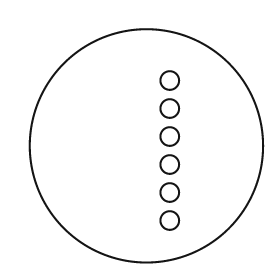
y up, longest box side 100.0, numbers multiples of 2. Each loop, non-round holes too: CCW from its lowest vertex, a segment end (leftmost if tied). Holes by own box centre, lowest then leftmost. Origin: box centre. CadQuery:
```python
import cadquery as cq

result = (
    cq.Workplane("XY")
    .moveTo(0.0, 0.0)
    .circle(50.0)
    .moveTo(10.0, -32.0)
    .circle(4.0)
    .moveTo(10.0, -20.0)
    .circle(4.0)
    .moveTo(10.0, -8.0)
    .circle(4.0)
    .moveTo(10.0, 4.0)
    .circle(4.0)
    .moveTo(10.0, 16.0)
    .circle(4.0)
    .moveTo(10.0, 28.0)
    .circle(4.0)
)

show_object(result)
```